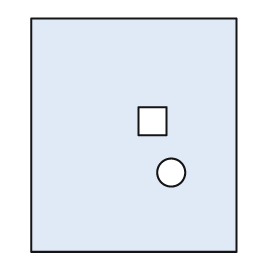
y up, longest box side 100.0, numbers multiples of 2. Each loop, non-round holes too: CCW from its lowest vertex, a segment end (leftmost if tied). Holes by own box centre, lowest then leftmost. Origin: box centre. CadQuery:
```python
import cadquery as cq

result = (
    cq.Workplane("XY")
    .moveTo(-44.0, -50.0)
    .lineTo(44.0, -50.0)
    .lineTo(44.0, 50.0)
    .lineTo(-44.0, 50.0)
    .close()
    .moveTo(16.0, -16.0)
    .circle(6.0)
    .moveTo(2.0, 0.0)
    .lineTo(14.0, 0.0)
    .lineTo(14.0, 12.0)
    .lineTo(2.0, 12.0)
    .close()
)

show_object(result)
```